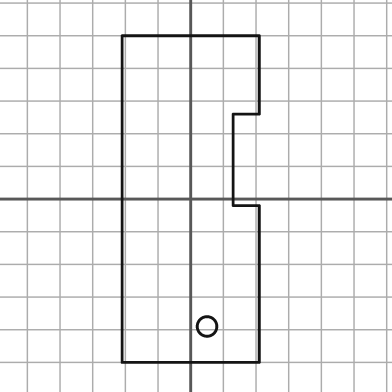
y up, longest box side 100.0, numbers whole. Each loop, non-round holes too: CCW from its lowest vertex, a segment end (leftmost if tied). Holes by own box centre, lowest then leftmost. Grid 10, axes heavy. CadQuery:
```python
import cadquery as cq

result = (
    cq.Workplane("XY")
    .moveTo(-21.0, -50.0)
    .lineTo(21.0, -50.0)
    .lineTo(21.0, -2.0)
    .lineTo(13.0, -2.0)
    .lineTo(13.0, 26.0)
    .lineTo(21.0, 26.0)
    .lineTo(21.0, 50.0)
    .lineTo(-21.0, 50.0)
    .close()
    .moveTo(5.0, -39.0)
    .circle(3.0)
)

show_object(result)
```